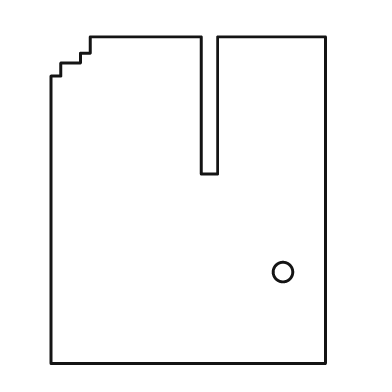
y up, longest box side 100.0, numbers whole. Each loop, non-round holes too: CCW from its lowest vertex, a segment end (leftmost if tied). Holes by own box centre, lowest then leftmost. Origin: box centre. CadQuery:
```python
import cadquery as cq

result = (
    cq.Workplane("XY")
    .moveTo(-42.0, -50.0)
    .lineTo(42.0, -50.0)
    .lineTo(42.0, 50.0)
    .lineTo(9.0, 50.0)
    .lineTo(9.0, 8.0)
    .lineTo(4.0, 8.0)
    .lineTo(4.0, 50.0)
    .lineTo(-30.0, 50.0)
    .lineTo(-30.0, 45.0)
    .lineTo(-33.0, 45.0)
    .lineTo(-33.0, 42.0)
    .lineTo(-39.0, 42.0)
    .lineTo(-39.0, 38.0)
    .lineTo(-42.0, 38.0)
    .close()
    .moveTo(29.0, -22.0)
    .circle(3.0)
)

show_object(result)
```